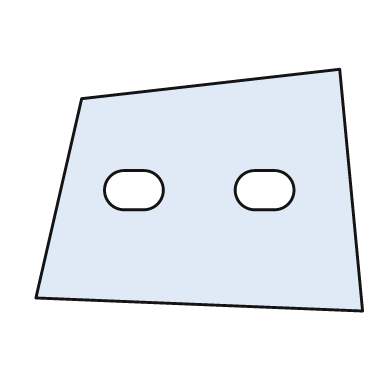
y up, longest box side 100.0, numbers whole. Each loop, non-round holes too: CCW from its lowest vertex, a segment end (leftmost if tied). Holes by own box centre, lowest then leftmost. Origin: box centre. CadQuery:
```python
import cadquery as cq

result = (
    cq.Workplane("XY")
    .moveTo(50.0, -37.0)
    .lineTo(43.0, 37.0)
    .lineTo(-36.0, 28.0)
    .lineTo(-50.0, -33.0)
    .close()
    .moveTo(-23.0, -6.0)
    .lineTo(-17.0, -6.0)
    .threePointArc((-11.0, 0.0), (-17.0, 6.0))
    .lineTo(-23.0, 6.0)
    .threePointArc((-29.0, 0.0), (-23.0, -6.0))
    .close()
    .moveTo(17.0, -6.0)
    .lineTo(23.0, -6.0)
    .threePointArc((29.0, 0.0), (23.0, 6.0))
    .lineTo(17.0, 6.0)
    .threePointArc((11.0, 0.0), (17.0, -6.0))
    .close()
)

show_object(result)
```